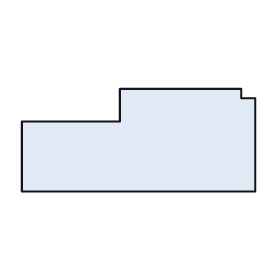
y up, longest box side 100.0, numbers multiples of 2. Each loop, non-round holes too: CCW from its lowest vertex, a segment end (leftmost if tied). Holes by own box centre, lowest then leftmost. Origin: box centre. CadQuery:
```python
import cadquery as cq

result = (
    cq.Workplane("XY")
    .moveTo(-50.0, -22.0)
    .lineTo(50.0, -22.0)
    .lineTo(50.0, 18.0)
    .lineTo(44.0, 18.0)
    .lineTo(44.0, 22.0)
    .lineTo(-8.0, 22.0)
    .lineTo(-8.0, 8.0)
    .lineTo(-50.0, 8.0)
    .close()
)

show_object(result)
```